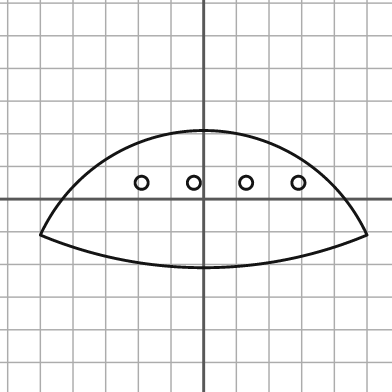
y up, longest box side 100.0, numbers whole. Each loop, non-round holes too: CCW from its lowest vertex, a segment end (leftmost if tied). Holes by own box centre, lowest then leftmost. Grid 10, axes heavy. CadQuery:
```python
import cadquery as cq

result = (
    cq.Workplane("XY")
    .moveTo(-50.0, -11.0)
    .threePointArc((0.0, -21.0), (50.0, -11.0))
    .threePointArc((0.0, 21.0), (-50.0, -11.0))
    .close()
    .moveTo(-19.0, 5.0)
    .circle(2.0)
    .moveTo(-3.0, 5.0)
    .circle(2.0)
    .moveTo(13.0, 5.0)
    .circle(2.0)
    .moveTo(29.0, 5.0)
    .circle(2.0)
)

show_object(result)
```